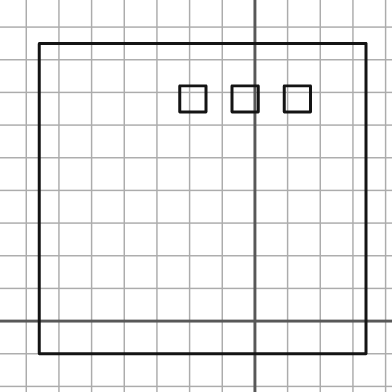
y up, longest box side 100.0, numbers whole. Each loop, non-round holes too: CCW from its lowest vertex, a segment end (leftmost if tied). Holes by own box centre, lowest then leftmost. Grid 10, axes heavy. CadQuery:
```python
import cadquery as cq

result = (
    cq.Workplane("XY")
    .moveTo(-66.0, -10.0)
    .lineTo(34.0, -10.0)
    .lineTo(34.0, 85.0)
    .lineTo(-66.0, 85.0)
    .close()
    .moveTo(-23.0, 64.0)
    .lineTo(-15.0, 64.0)
    .lineTo(-15.0, 72.0)
    .lineTo(-23.0, 72.0)
    .close()
    .moveTo(-7.0, 64.0)
    .lineTo(1.0, 64.0)
    .lineTo(1.0, 72.0)
    .lineTo(-7.0, 72.0)
    .close()
    .moveTo(9.0, 64.0)
    .lineTo(17.0, 64.0)
    .lineTo(17.0, 72.0)
    .lineTo(9.0, 72.0)
    .close()
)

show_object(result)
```